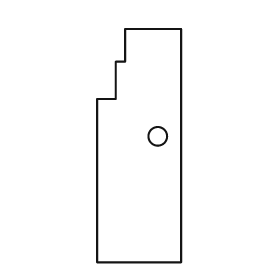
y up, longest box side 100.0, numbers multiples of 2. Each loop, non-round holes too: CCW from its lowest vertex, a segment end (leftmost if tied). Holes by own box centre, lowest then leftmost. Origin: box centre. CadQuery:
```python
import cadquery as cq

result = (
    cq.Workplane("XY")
    .moveTo(-18.0, -50.0)
    .lineTo(18.0, -50.0)
    .lineTo(18.0, 50.0)
    .lineTo(-6.0, 50.0)
    .lineTo(-6.0, 36.0)
    .lineTo(-10.0, 36.0)
    .lineTo(-10.0, 20.0)
    .lineTo(-18.0, 20.0)
    .close()
    .moveTo(8.0, 4.0)
    .circle(4.0)
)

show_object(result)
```